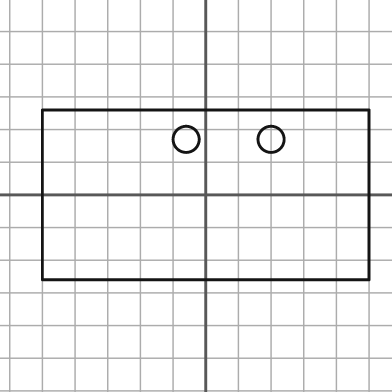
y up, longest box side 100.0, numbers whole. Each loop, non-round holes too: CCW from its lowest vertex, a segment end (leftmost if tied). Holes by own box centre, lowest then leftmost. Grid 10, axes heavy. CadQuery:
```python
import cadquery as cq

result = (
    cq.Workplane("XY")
    .moveTo(-50.0, -26.0)
    .lineTo(50.0, -26.0)
    .lineTo(50.0, 26.0)
    .lineTo(-50.0, 26.0)
    .close()
    .moveTo(-6.0, 17.0)
    .circle(4.0)
    .moveTo(20.0, 17.0)
    .circle(4.0)
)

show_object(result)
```